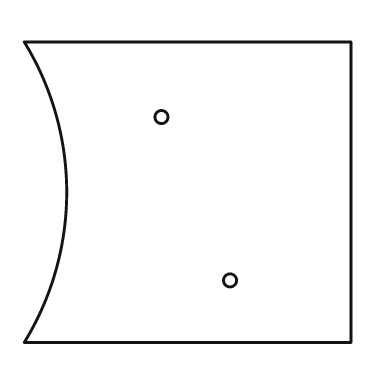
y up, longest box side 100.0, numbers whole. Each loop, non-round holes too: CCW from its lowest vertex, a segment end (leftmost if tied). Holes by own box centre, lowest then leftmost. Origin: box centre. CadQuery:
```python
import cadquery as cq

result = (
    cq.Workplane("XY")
    .moveTo(-50.0, -46.0)
    .lineTo(50.0, -46.0)
    .lineTo(50.0, 46.0)
    .lineTo(-50.0, 46.0)
    .threePointArc((-37.0, 0.0), (-50.0, -46.0))
    .close()
    .moveTo(13.0, -27.0)
    .circle(2.0)
    .moveTo(-8.0, 23.0)
    .circle(2.0)
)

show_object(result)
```